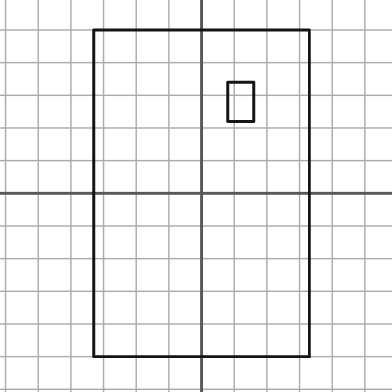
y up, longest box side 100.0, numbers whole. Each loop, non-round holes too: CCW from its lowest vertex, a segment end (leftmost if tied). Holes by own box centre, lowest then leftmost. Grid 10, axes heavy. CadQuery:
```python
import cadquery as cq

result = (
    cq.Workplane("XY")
    .moveTo(-33.0, -50.0)
    .lineTo(33.0, -50.0)
    .lineTo(33.0, 50.0)
    .lineTo(-33.0, 50.0)
    .close()
    .moveTo(8.0, 22.0)
    .lineTo(16.0, 22.0)
    .lineTo(16.0, 34.0)
    .lineTo(8.0, 34.0)
    .close()
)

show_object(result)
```